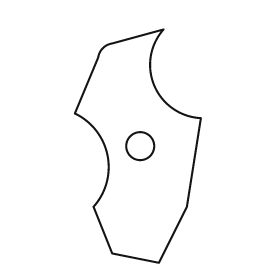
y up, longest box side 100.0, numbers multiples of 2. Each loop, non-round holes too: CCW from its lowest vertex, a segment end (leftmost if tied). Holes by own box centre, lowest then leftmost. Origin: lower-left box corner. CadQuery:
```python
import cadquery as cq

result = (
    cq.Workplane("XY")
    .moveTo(36.0, 0.0)
    .lineTo(48.0, 24.0)
    .lineTo(54.0, 62.0)
    .threePointArc((34.0, 76.0), (38.0, 100.0))
    .lineTo(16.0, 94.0)
    .threePointArc((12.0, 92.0), (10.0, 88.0))
    .lineTo(0.0, 64.0)
    .threePointArc((14.0, 46.0), (8.0, 24.0))
    .lineTo(16.0, 4.0)
    .close()
    .moveTo(28.0, 50.0)
    .circle(6.0)
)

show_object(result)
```